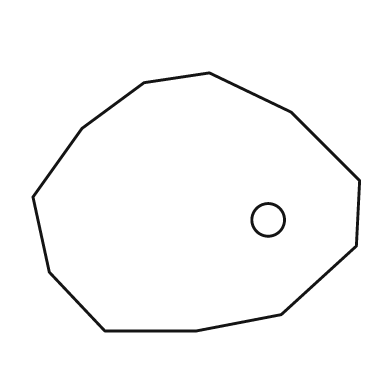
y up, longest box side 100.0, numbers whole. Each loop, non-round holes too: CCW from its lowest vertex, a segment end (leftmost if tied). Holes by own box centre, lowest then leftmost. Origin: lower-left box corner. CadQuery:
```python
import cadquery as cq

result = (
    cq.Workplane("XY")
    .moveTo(22.0, 0.0)
    .lineTo(50.0, 0.0)
    .lineTo(76.0, 5.0)
    .lineTo(99.0, 26.0)
    .lineTo(100.0, 46.0)
    .lineTo(79.0, 67.0)
    .lineTo(54.0, 79.0)
    .lineTo(34.0, 76.0)
    .lineTo(15.0, 62.0)
    .lineTo(0.0, 41.0)
    .lineTo(5.0, 18.0)
    .close()
    .moveTo(72.0, 34.0)
    .circle(5.0)
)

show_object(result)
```